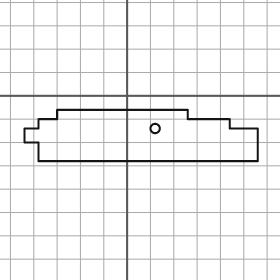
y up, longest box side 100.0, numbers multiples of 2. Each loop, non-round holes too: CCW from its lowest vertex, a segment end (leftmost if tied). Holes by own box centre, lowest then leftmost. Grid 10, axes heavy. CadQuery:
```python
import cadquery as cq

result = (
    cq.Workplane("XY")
    .moveTo(-38.0, -28.0)
    .lineTo(56.0, -28.0)
    .lineTo(56.0, -14.0)
    .lineTo(44.0, -14.0)
    .lineTo(44.0, -10.0)
    .lineTo(26.0, -10.0)
    .lineTo(26.0, -6.0)
    .lineTo(-30.0, -6.0)
    .lineTo(-30.0, -10.0)
    .lineTo(-38.0, -10.0)
    .lineTo(-38.0, -14.0)
    .lineTo(-44.0, -14.0)
    .lineTo(-44.0, -20.0)
    .lineTo(-38.0, -20.0)
    .close()
    .moveTo(12.0, -14.0)
    .circle(2.0)
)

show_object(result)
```